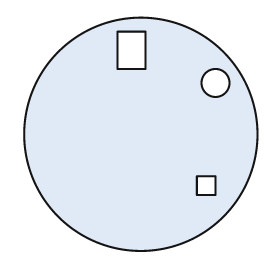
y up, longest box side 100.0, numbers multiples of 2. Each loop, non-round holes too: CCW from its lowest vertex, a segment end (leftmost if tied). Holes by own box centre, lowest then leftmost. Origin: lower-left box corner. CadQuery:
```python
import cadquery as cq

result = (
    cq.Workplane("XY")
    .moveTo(50.0, 50.0)
    .circle(50.0)
    .moveTo(74.0, 24.0)
    .lineTo(82.0, 24.0)
    .lineTo(82.0, 32.0)
    .lineTo(74.0, 32.0)
    .close()
    .moveTo(82.0, 72.0)
    .circle(6.0)
    .moveTo(40.0, 78.0)
    .lineTo(52.0, 78.0)
    .lineTo(52.0, 94.0)
    .lineTo(40.0, 94.0)
    .close()
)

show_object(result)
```